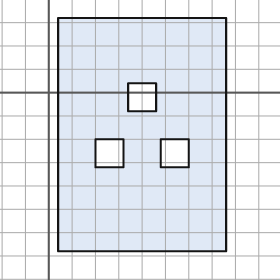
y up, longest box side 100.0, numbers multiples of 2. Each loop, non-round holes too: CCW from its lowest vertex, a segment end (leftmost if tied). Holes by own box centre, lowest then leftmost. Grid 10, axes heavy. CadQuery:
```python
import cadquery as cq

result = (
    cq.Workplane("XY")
    .moveTo(4.0, -68.0)
    .lineTo(76.0, -68.0)
    .lineTo(76.0, 32.0)
    .lineTo(4.0, 32.0)
    .close()
    .moveTo(20.0, -32.0)
    .lineTo(32.0, -32.0)
    .lineTo(32.0, -20.0)
    .lineTo(20.0, -20.0)
    .close()
    .moveTo(48.0, -32.0)
    .lineTo(60.0, -32.0)
    .lineTo(60.0, -20.0)
    .lineTo(48.0, -20.0)
    .close()
    .moveTo(34.0, -8.0)
    .lineTo(46.0, -8.0)
    .lineTo(46.0, 4.0)
    .lineTo(34.0, 4.0)
    .close()
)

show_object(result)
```